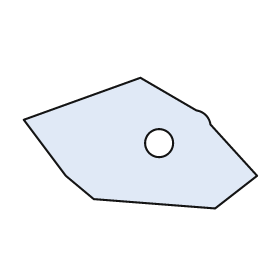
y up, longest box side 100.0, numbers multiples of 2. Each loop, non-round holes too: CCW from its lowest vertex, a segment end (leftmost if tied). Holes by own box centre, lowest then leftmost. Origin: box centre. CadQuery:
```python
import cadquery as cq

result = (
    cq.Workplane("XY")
    .moveTo(32.0, -28.0)
    .lineTo(50.0, -14.0)
    .lineTo(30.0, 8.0)
    .threePointArc((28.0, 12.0), (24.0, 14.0))
    .lineTo(0.0, 28.0)
    .lineTo(-50.0, 10.0)
    .lineTo(-32.0, -14.0)
    .lineTo(-20.0, -24.0)
    .close()
    .moveTo(8.0, 0.0)
    .circle(6.0)
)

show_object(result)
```